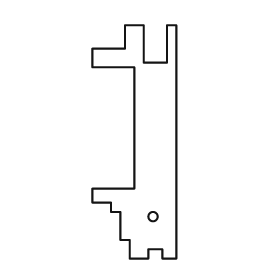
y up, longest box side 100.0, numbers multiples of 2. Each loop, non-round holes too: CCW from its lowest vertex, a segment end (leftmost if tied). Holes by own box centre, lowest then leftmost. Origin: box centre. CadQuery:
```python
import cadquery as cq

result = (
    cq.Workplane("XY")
    .moveTo(-2.0, -50.0)
    .lineTo(6.0, -50.0)
    .lineTo(6.0, -46.0)
    .lineTo(12.0, -46.0)
    .lineTo(12.0, -50.0)
    .lineTo(18.0, -50.0)
    .lineTo(18.0, 50.0)
    .lineTo(14.0, 50.0)
    .lineTo(14.0, 34.0)
    .lineTo(4.0, 34.0)
    .lineTo(4.0, 50.0)
    .lineTo(-4.0, 50.0)
    .lineTo(-4.0, 40.0)
    .lineTo(-18.0, 40.0)
    .lineTo(-18.0, 32.0)
    .lineTo(0.0, 32.0)
    .lineTo(0.0, -20.0)
    .lineTo(-18.0, -20.0)
    .lineTo(-18.0, -26.0)
    .lineTo(-10.0, -26.0)
    .lineTo(-10.0, -30.0)
    .lineTo(-6.0, -30.0)
    .lineTo(-6.0, -42.0)
    .lineTo(-2.0, -42.0)
    .close()
    .moveTo(8.0, -32.0)
    .circle(2.0)
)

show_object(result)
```